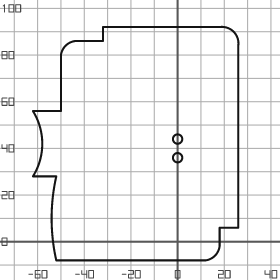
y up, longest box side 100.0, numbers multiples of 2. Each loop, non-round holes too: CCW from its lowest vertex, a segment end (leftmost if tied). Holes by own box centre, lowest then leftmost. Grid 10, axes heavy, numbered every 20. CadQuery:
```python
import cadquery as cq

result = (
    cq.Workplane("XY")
    .moveTo(-52.0, -8.0)
    .lineTo(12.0, -8.0)
    .threePointArc((16.0, -6.0), (18.0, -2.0))
    .lineTo(18.0, 6.0)
    .lineTo(26.0, 6.0)
    .lineTo(26.0, 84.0)
    .threePointArc((24.0, 90.0), (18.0, 92.0))
    .lineTo(-32.0, 92.0)
    .lineTo(-32.0, 86.0)
    .lineTo(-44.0, 86.0)
    .threePointArc((-48.0, 84.0), (-50.0, 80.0))
    .lineTo(-50.0, 56.0)
    .lineTo(-62.0, 56.0)
    .threePointArc((-58.0, 42.0), (-62.0, 28.0))
    .lineTo(-52.0, 28.0)
    .threePointArc((-54.0, 10.0), (-52.0, -8.0))
    .close()
    .moveTo(0.0, 36.0)
    .circle(2.0)
    .moveTo(0.0, 44.0)
    .circle(2.0)
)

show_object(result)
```